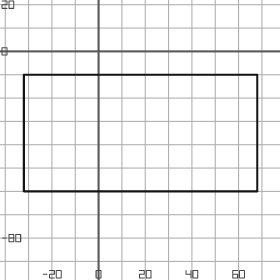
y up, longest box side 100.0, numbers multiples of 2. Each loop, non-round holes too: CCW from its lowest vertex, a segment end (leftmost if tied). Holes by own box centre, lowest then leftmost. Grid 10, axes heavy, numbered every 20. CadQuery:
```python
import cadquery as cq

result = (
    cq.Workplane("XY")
    .moveTo(-32.0, -60.0)
    .lineTo(68.0, -60.0)
    .lineTo(68.0, -10.0)
    .lineTo(-32.0, -10.0)
    .close()
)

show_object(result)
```